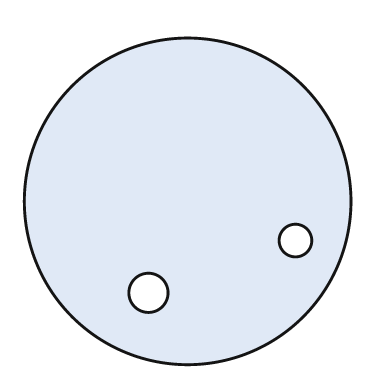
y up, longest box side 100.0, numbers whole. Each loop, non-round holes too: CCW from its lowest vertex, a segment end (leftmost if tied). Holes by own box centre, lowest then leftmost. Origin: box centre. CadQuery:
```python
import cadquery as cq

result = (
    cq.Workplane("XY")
    .moveTo(0.0, 0.0)
    .circle(50.0)
    .moveTo(-12.0, -28.0)
    .circle(6.0)
    .moveTo(33.0, -12.0)
    .circle(5.0)
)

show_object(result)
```